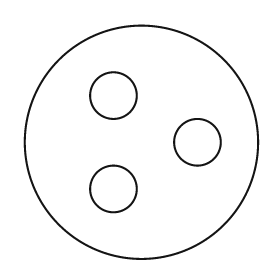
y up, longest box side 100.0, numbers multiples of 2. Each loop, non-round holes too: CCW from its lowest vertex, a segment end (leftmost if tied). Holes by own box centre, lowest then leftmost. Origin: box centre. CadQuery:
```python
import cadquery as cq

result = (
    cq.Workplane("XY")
    .moveTo(0.0, 0.0)
    .circle(50.0)
    .moveTo(-12.0, -20.0)
    .circle(10.0)
    .moveTo(24.0, 0.0)
    .circle(10.0)
    .moveTo(-12.0, 20.0)
    .circle(10.0)
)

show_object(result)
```